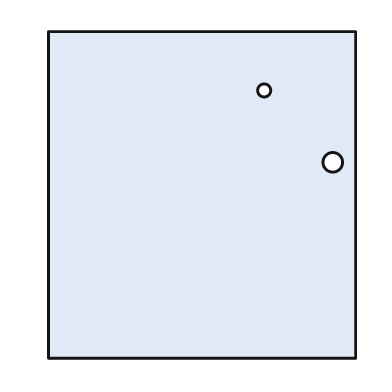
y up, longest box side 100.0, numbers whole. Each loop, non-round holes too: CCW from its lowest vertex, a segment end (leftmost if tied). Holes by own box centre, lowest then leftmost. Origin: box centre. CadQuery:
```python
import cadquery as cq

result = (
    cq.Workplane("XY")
    .moveTo(-47.0, -50.0)
    .lineTo(47.0, -50.0)
    .lineTo(47.0, 50.0)
    .lineTo(-47.0, 50.0)
    .close()
    .moveTo(40.0, 10.0)
    .circle(3.0)
    .moveTo(19.0, 32.0)
    .circle(2.0)
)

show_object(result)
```